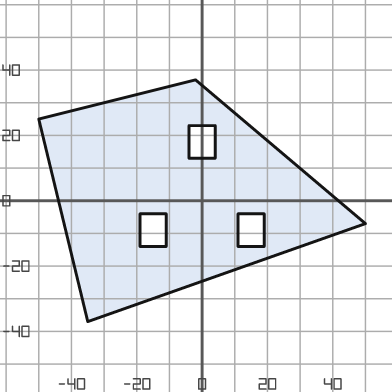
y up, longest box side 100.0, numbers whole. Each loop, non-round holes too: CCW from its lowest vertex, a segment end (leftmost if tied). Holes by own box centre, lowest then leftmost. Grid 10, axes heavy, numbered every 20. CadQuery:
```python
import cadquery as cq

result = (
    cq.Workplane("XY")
    .moveTo(-35.0, -37.0)
    .lineTo(50.0, -7.0)
    .lineTo(-2.0, 37.0)
    .lineTo(-50.0, 25.0)
    .close()
    .moveTo(-19.0, -14.0)
    .lineTo(-11.0, -14.0)
    .lineTo(-11.0, -4.0)
    .lineTo(-19.0, -4.0)
    .close()
    .moveTo(11.0, -14.0)
    .lineTo(19.0, -14.0)
    .lineTo(19.0, -4.0)
    .lineTo(11.0, -4.0)
    .close()
    .moveTo(-4.0, 13.0)
    .lineTo(4.0, 13.0)
    .lineTo(4.0, 23.0)
    .lineTo(-4.0, 23.0)
    .close()
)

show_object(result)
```